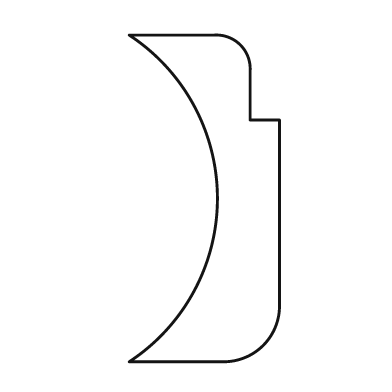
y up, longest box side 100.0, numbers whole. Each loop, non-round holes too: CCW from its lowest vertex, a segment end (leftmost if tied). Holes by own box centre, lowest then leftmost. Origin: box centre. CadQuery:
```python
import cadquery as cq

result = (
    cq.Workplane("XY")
    .moveTo(-23.0, -50.0)
    .lineTo(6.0, -50.0)
    .threePointArc((18.0, -45.0), (23.0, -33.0))
    .lineTo(23.0, 24.0)
    .lineTo(14.0, 24.0)
    .lineTo(14.0, 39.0)
    .threePointArc((11.0, 47.0), (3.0, 50.0))
    .lineTo(-23.0, 50.0)
    .threePointArc((4.0, 0.0), (-23.0, -50.0))
    .close()
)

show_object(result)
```